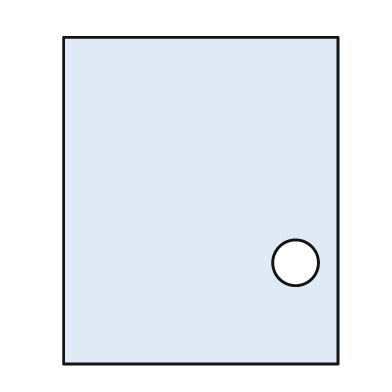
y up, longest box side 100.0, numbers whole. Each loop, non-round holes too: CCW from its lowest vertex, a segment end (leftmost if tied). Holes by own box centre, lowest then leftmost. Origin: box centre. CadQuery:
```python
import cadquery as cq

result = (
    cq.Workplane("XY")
    .moveTo(-42.0, -50.0)
    .lineTo(42.0, -50.0)
    .lineTo(42.0, 50.0)
    .lineTo(-42.0, 50.0)
    .close()
    .moveTo(29.0, -19.0)
    .circle(7.0)
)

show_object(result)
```